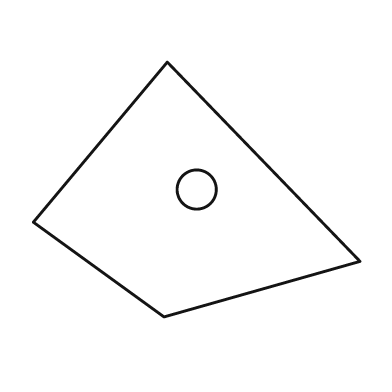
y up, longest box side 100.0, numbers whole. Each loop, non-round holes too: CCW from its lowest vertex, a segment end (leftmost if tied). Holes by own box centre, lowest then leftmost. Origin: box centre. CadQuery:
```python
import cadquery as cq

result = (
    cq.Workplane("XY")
    .moveTo(-10.0, -39.0)
    .lineTo(50.0, -22.0)
    .lineTo(-9.0, 39.0)
    .lineTo(-50.0, -10.0)
    .close()
    .moveTo(0.0, 0.0)
    .circle(6.0)
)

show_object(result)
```